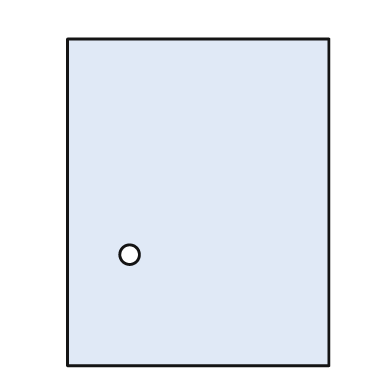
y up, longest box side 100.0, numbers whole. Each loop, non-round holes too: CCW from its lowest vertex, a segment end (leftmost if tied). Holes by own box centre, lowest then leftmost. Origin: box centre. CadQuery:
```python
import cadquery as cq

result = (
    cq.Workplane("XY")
    .moveTo(-40.0, -50.0)
    .lineTo(40.0, -50.0)
    .lineTo(40.0, 50.0)
    .lineTo(-40.0, 50.0)
    .close()
    .moveTo(-21.0, -16.0)
    .circle(3.0)
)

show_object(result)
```